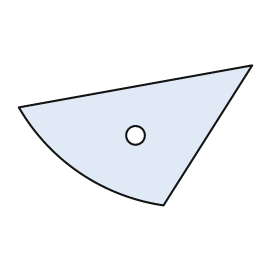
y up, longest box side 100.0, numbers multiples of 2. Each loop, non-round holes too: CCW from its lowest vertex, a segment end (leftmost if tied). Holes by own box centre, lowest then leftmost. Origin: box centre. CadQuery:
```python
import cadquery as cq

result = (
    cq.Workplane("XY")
    .moveTo(12.0, -30.0)
    .lineTo(50.0, 30.0)
    .lineTo(-50.0, 12.0)
    .threePointArc((-24.0, -16.0), (12.0, -30.0))
    .close()
    .moveTo(0.0, 0.0)
    .circle(4.0)
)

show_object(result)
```